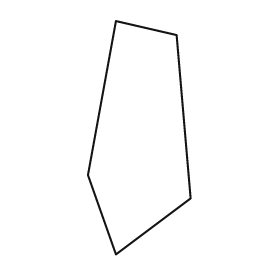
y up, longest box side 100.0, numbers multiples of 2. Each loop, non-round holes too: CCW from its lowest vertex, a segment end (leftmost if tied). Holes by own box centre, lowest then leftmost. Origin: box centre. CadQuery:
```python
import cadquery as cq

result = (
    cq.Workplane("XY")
    .moveTo(-10.0, -50.0)
    .lineTo(22.0, -26.0)
    .lineTo(16.0, 44.0)
    .lineTo(-10.0, 50.0)
    .lineTo(-22.0, -16.0)
    .close()
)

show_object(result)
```